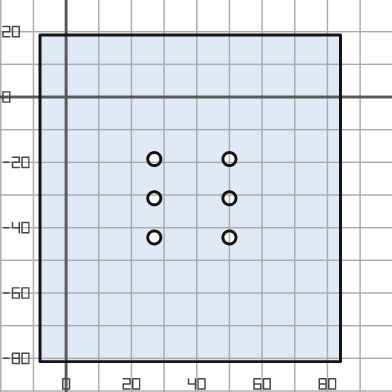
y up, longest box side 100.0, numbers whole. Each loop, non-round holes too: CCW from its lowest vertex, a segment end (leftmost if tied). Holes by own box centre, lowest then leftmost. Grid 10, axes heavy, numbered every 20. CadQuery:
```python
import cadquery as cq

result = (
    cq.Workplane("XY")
    .moveTo(-8.0, -81.0)
    .lineTo(84.0, -81.0)
    .lineTo(84.0, 19.0)
    .lineTo(-8.0, 19.0)
    .close()
    .moveTo(27.0, -43.0)
    .circle(2.0)
    .moveTo(50.0, -43.0)
    .circle(2.0)
    .moveTo(27.0, -31.0)
    .circle(2.0)
    .moveTo(50.0, -31.0)
    .circle(2.0)
    .moveTo(27.0, -19.0)
    .circle(2.0)
    .moveTo(50.0, -19.0)
    .circle(2.0)
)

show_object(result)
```